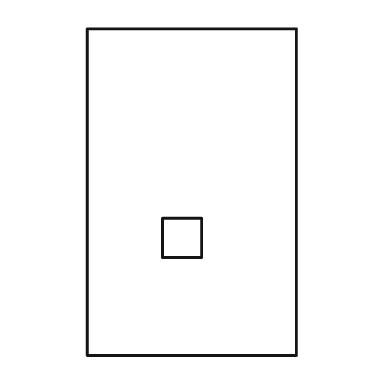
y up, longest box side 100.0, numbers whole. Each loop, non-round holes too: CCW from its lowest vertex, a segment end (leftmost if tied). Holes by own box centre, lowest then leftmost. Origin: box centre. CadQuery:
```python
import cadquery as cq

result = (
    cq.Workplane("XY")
    .moveTo(-32.0, -50.0)
    .lineTo(32.0, -50.0)
    .lineTo(32.0, 50.0)
    .lineTo(-32.0, 50.0)
    .close()
    .moveTo(-9.0, -20.0)
    .lineTo(3.0, -20.0)
    .lineTo(3.0, -8.0)
    .lineTo(-9.0, -8.0)
    .close()
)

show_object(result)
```